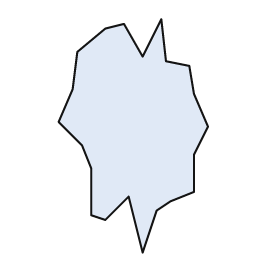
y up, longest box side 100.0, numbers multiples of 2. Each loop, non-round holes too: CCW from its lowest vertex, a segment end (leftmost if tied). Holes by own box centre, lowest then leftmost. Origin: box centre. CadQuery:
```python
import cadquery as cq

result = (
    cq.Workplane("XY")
    .moveTo(4.0, -50.0)
    .lineTo(10.0, -32.0)
    .lineTo(16.0, -28.0)
    .lineTo(26.0, -24.0)
    .lineTo(26.0, -8.0)
    .lineTo(32.0, 4.0)
    .lineTo(26.0, 18.0)
    .lineTo(24.0, 30.0)
    .lineTo(14.0, 32.0)
    .lineTo(12.0, 50.0)
    .lineTo(4.0, 34.0)
    .lineTo(-4.0, 48.0)
    .lineTo(-12.0, 46.0)
    .lineTo(-24.0, 36.0)
    .lineTo(-26.0, 20.0)
    .lineTo(-32.0, 6.0)
    .lineTo(-22.0, -4.0)
    .lineTo(-18.0, -14.0)
    .lineTo(-18.0, -34.0)
    .lineTo(-12.0, -36.0)
    .lineTo(-2.0, -26.0)
    .close()
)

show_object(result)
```